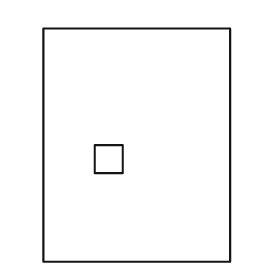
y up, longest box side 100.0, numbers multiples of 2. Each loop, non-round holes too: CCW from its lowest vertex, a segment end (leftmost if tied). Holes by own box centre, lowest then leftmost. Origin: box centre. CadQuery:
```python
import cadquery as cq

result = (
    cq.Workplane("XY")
    .moveTo(-40.0, -50.0)
    .lineTo(40.0, -50.0)
    .lineTo(40.0, 50.0)
    .lineTo(-40.0, 50.0)
    .close()
    .moveTo(-18.0, -12.0)
    .lineTo(-6.0, -12.0)
    .lineTo(-6.0, 0.0)
    .lineTo(-18.0, 0.0)
    .close()
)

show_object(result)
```